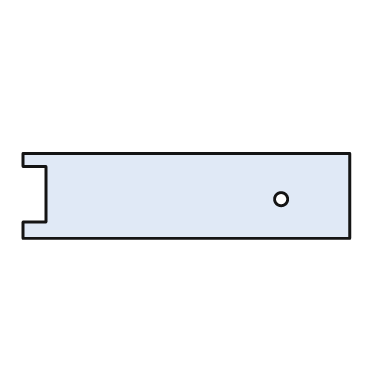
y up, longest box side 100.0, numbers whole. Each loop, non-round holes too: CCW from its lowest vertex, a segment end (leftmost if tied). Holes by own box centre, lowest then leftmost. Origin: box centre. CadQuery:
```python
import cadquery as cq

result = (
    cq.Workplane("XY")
    .moveTo(-50.0, -13.0)
    .lineTo(50.0, -13.0)
    .lineTo(50.0, 13.0)
    .lineTo(-50.0, 13.0)
    .lineTo(-50.0, 9.0)
    .lineTo(-43.0, 9.0)
    .lineTo(-43.0, -8.0)
    .lineTo(-50.0, -8.0)
    .close()
    .moveTo(29.0, -1.0)
    .circle(2.0)
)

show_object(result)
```